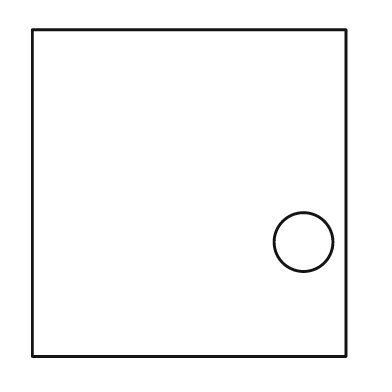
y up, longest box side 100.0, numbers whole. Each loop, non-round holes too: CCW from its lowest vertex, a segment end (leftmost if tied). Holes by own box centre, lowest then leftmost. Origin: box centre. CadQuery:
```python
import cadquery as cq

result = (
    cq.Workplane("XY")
    .moveTo(-48.0, -50.0)
    .lineTo(48.0, -50.0)
    .lineTo(48.0, 50.0)
    .lineTo(-48.0, 50.0)
    .close()
    .moveTo(35.0, -15.0)
    .circle(9.0)
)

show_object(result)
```